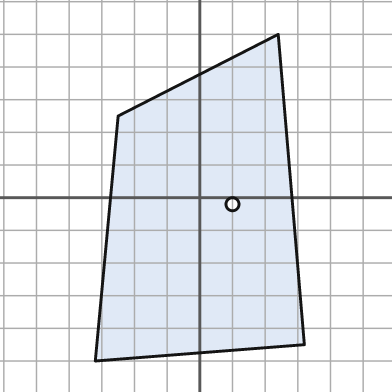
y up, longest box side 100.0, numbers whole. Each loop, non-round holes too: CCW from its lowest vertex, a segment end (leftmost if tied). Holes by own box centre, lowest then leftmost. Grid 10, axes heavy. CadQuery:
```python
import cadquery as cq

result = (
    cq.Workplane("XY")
    .moveTo(-32.0, -50.0)
    .lineTo(32.0, -45.0)
    .lineTo(24.0, 50.0)
    .lineTo(-25.0, 25.0)
    .close()
    .moveTo(10.0, -2.0)
    .circle(2.0)
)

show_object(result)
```